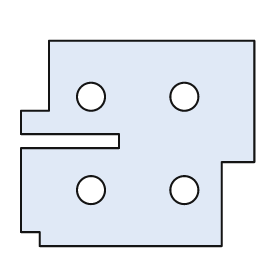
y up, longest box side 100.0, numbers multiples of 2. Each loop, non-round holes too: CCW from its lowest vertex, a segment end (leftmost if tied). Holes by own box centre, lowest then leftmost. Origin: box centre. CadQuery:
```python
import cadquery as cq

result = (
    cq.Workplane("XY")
    .moveTo(-42.0, -44.0)
    .lineTo(36.0, -44.0)
    .lineTo(36.0, -8.0)
    .lineTo(50.0, -8.0)
    .lineTo(50.0, 44.0)
    .lineTo(-38.0, 44.0)
    .lineTo(-38.0, 14.0)
    .lineTo(-50.0, 14.0)
    .lineTo(-50.0, 4.0)
    .lineTo(-8.0, 4.0)
    .lineTo(-8.0, -2.0)
    .lineTo(-50.0, -2.0)
    .lineTo(-50.0, -38.0)
    .lineTo(-42.0, -38.0)
    .close()
    .moveTo(-20.0, -20.0)
    .circle(6.0)
    .moveTo(20.0, -20.0)
    .circle(6.0)
    .moveTo(-20.0, 20.0)
    .circle(6.0)
    .moveTo(20.0, 20.0)
    .circle(6.0)
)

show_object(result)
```